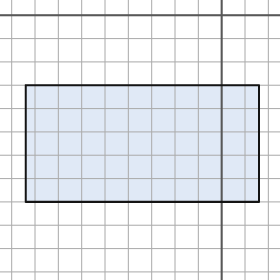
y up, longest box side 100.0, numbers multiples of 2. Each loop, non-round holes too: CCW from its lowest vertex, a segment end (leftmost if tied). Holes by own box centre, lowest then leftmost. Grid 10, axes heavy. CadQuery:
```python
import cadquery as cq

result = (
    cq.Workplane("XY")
    .moveTo(-84.0, -80.0)
    .lineTo(16.0, -80.0)
    .lineTo(16.0, -30.0)
    .lineTo(-84.0, -30.0)
    .close()
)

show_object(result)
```